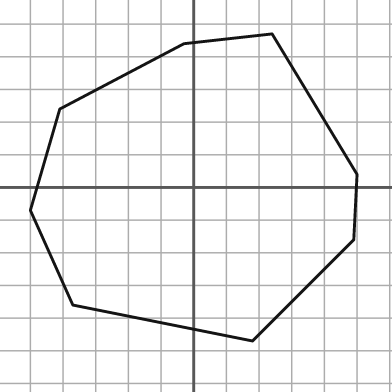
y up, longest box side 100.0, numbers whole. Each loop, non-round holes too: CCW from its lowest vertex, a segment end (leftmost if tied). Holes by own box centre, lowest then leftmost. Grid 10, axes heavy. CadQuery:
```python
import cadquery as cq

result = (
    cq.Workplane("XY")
    .moveTo(18.0, -47.0)
    .lineTo(49.0, -16.0)
    .lineTo(50.0, 4.0)
    .lineTo(24.0, 47.0)
    .lineTo(-3.0, 44.0)
    .lineTo(-41.0, 24.0)
    .lineTo(-50.0, -7.0)
    .lineTo(-37.0, -36.0)
    .close()
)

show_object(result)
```